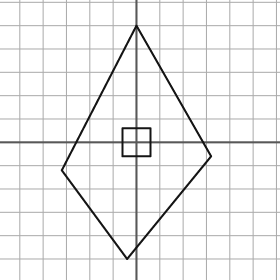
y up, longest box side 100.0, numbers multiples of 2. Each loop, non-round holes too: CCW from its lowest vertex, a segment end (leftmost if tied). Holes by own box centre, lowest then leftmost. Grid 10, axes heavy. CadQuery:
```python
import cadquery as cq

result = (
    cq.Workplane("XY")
    .moveTo(-4.0, -50.0)
    .lineTo(32.0, -6.0)
    .lineTo(0.0, 50.0)
    .lineTo(-32.0, -12.0)
    .close()
    .moveTo(-6.0, -6.0)
    .lineTo(6.0, -6.0)
    .lineTo(6.0, 6.0)
    .lineTo(-6.0, 6.0)
    .close()
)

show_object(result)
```